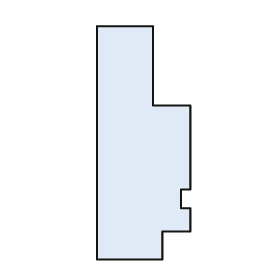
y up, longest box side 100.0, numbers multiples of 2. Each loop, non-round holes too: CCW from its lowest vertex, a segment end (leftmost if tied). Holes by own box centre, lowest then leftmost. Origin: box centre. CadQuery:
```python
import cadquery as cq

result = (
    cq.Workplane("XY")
    .moveTo(-20.0, -50.0)
    .lineTo(8.0, -50.0)
    .lineTo(8.0, -38.0)
    .lineTo(20.0, -38.0)
    .lineTo(20.0, -28.0)
    .lineTo(16.0, -28.0)
    .lineTo(16.0, -20.0)
    .lineTo(20.0, -20.0)
    .lineTo(20.0, 16.0)
    .lineTo(4.0, 16.0)
    .lineTo(4.0, 50.0)
    .lineTo(-20.0, 50.0)
    .close()
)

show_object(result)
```